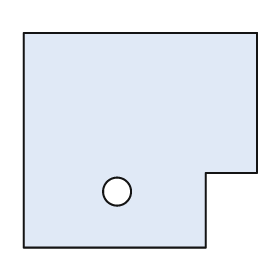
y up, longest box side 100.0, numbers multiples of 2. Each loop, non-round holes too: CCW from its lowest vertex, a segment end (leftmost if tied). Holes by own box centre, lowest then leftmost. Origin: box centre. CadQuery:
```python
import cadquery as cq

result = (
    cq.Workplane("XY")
    .moveTo(-50.0, -46.0)
    .lineTo(28.0, -46.0)
    .lineTo(28.0, -14.0)
    .lineTo(50.0, -14.0)
    .lineTo(50.0, 46.0)
    .lineTo(-50.0, 46.0)
    .close()
    .moveTo(-10.0, -22.0)
    .circle(6.0)
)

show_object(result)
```